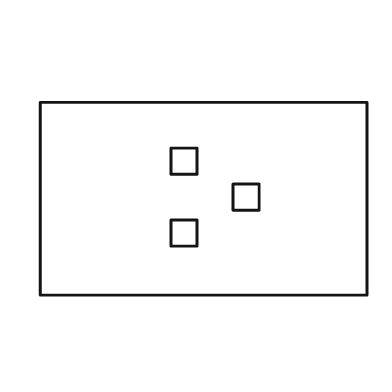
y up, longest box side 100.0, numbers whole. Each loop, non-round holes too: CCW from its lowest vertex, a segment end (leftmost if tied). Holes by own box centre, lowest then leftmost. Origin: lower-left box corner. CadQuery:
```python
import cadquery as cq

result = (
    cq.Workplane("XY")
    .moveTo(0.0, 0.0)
    .lineTo(100.0, 0.0)
    .lineTo(100.0, 59.0)
    .lineTo(0.0, 59.0)
    .close()
    .moveTo(40.0, 15.0)
    .lineTo(48.0, 15.0)
    .lineTo(48.0, 23.0)
    .lineTo(40.0, 23.0)
    .close()
    .moveTo(59.0, 26.0)
    .lineTo(67.0, 26.0)
    .lineTo(67.0, 34.0)
    .lineTo(59.0, 34.0)
    .close()
    .moveTo(40.0, 37.0)
    .lineTo(48.0, 37.0)
    .lineTo(48.0, 45.0)
    .lineTo(40.0, 45.0)
    .close()
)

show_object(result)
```